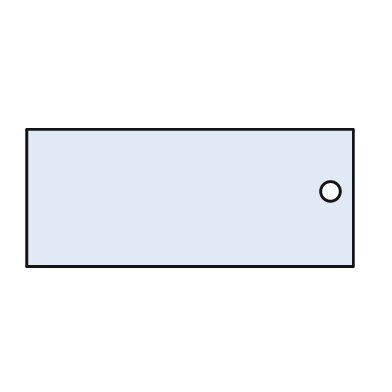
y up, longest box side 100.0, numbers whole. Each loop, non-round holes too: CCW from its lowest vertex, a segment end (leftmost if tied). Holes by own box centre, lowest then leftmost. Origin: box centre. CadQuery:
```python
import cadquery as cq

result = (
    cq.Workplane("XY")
    .moveTo(-50.0, -21.0)
    .lineTo(50.0, -21.0)
    .lineTo(50.0, 21.0)
    .lineTo(-50.0, 21.0)
    .close()
    .moveTo(43.0, 2.0)
    .circle(3.0)
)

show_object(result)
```